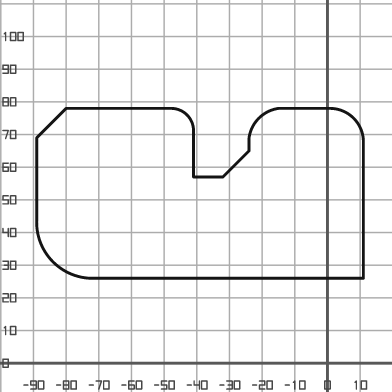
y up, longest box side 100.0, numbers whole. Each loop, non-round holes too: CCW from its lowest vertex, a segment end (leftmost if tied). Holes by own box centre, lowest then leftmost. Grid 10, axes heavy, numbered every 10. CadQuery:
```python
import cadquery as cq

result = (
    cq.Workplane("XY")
    .moveTo(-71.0, 26.0)
    .lineTo(11.0, 26.0)
    .lineTo(11.0, 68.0)
    .threePointArc((8.0, 75.0), (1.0, 78.0))
    .lineTo(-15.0, 78.0)
    .threePointArc((-21.0, 75.0), (-24.0, 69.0))
    .lineTo(-24.0, 65.0)
    .lineTo(-32.0, 57.0)
    .lineTo(-41.0, 57.0)
    .lineTo(-41.0, 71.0)
    .threePointArc((-43.0, 76.0), (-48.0, 78.0))
    .lineTo(-80.0, 78.0)
    .lineTo(-89.0, 69.0)
    .lineTo(-89.0, 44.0)
    .threePointArc((-84.0, 31.0), (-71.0, 26.0))
    .close()
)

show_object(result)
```